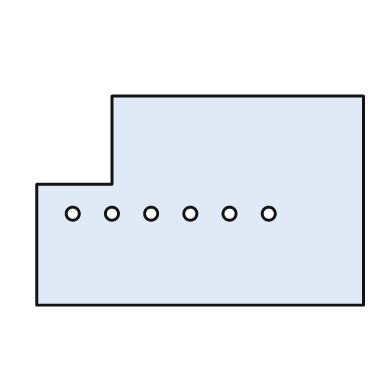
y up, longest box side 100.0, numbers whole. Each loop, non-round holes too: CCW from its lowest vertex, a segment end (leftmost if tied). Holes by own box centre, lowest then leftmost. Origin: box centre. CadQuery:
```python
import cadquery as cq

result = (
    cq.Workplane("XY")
    .moveTo(-50.0, -32.0)
    .lineTo(50.0, -32.0)
    .lineTo(50.0, 32.0)
    .lineTo(-27.0, 32.0)
    .lineTo(-27.0, 5.0)
    .lineTo(-50.0, 5.0)
    .close()
    .moveTo(-39.0, -4.0)
    .circle(2.0)
    .moveTo(-27.0, -4.0)
    .circle(2.0)
    .moveTo(-15.0, -4.0)
    .circle(2.0)
    .moveTo(-3.0, -4.0)
    .circle(2.0)
    .moveTo(9.0, -4.0)
    .circle(2.0)
    .moveTo(21.0, -4.0)
    .circle(2.0)
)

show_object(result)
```